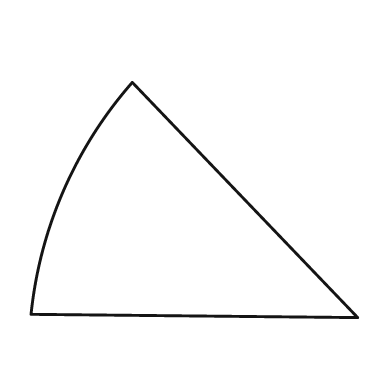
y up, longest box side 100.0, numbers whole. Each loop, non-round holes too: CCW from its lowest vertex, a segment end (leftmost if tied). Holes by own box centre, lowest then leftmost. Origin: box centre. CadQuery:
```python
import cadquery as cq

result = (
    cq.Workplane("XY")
    .moveTo(50.0, -36.0)
    .lineTo(-19.0, 36.0)
    .threePointArc((-40.0, 3.0), (-50.0, -35.0))
    .close()
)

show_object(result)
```